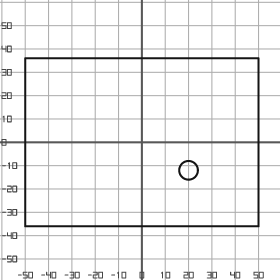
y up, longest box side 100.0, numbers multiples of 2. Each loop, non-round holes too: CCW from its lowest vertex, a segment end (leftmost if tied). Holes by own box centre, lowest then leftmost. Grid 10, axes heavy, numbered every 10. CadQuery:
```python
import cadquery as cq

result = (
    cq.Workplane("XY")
    .moveTo(-50.0, -36.0)
    .lineTo(50.0, -36.0)
    .lineTo(50.0, 36.0)
    .lineTo(-50.0, 36.0)
    .close()
    .moveTo(20.0, -12.0)
    .circle(4.0)
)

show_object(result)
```